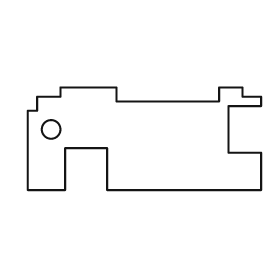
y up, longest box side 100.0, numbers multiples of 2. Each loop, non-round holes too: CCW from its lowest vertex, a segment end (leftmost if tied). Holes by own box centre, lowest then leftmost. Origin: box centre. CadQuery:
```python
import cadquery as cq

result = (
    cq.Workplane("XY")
    .moveTo(-50.0, -22.0)
    .lineTo(-34.0, -22.0)
    .lineTo(-34.0, -4.0)
    .lineTo(-16.0, -4.0)
    .lineTo(-16.0, -22.0)
    .lineTo(50.0, -22.0)
    .lineTo(50.0, -6.0)
    .lineTo(36.0, -6.0)
    .lineTo(36.0, 14.0)
    .lineTo(50.0, 14.0)
    .lineTo(50.0, 18.0)
    .lineTo(42.0, 18.0)
    .lineTo(42.0, 22.0)
    .lineTo(32.0, 22.0)
    .lineTo(32.0, 16.0)
    .lineTo(-12.0, 16.0)
    .lineTo(-12.0, 22.0)
    .lineTo(-36.0, 22.0)
    .lineTo(-36.0, 18.0)
    .lineTo(-46.0, 18.0)
    .lineTo(-46.0, 12.0)
    .lineTo(-50.0, 12.0)
    .close()
    .moveTo(-40.0, 4.0)
    .circle(4.0)
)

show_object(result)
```